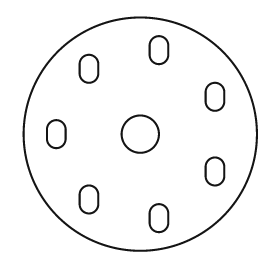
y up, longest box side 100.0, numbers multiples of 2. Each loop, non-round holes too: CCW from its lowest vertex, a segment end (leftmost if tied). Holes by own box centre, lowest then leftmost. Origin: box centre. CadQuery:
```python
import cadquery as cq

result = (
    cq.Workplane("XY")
    .moveTo(0.0, 0.0)
    .circle(50.0)
    .moveTo(4.0, -38.0)
    .threePointArc((8.0, -42.0), (12.0, -38.0))
    .lineTo(12.0, -34.0)
    .threePointArc((8.0, -30.0), (4.0, -34.0))
    .close()
    .moveTo(-26.0, -30.0)
    .threePointArc((-22.0, -34.0), (-18.0, -30.0))
    .lineTo(-18.0, -26.0)
    .threePointArc((-22.0, -22.0), (-26.0, -26.0))
    .close()
    .moveTo(28.0, -18.0)
    .threePointArc((32.0, -22.0), (36.0, -18.0))
    .lineTo(36.0, -14.0)
    .threePointArc((32.0, -10.0), (28.0, -14.0))
    .close()
    .moveTo(-40.0, -2.0)
    .threePointArc((-36.0, -6.0), (-32.0, -2.0))
    .lineTo(-32.0, 2.0)
    .threePointArc((-36.0, 6.0), (-40.0, 2.0))
    .close()
    .moveTo(0.0, 0.0)
    .circle(8.0)
    .moveTo(28.0, 14.0)
    .threePointArc((32.0, 10.0), (36.0, 14.0))
    .lineTo(36.0, 18.0)
    .threePointArc((32.0, 22.0), (28.0, 18.0))
    .close()
    .moveTo(-26.0, 26.0)
    .threePointArc((-22.0, 22.0), (-18.0, 26.0))
    .lineTo(-18.0, 30.0)
    .threePointArc((-22.0, 34.0), (-26.0, 30.0))
    .close()
    .moveTo(4.0, 34.0)
    .threePointArc((8.0, 30.0), (12.0, 34.0))
    .lineTo(12.0, 38.0)
    .threePointArc((8.0, 42.0), (4.0, 38.0))
    .close()
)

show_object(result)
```